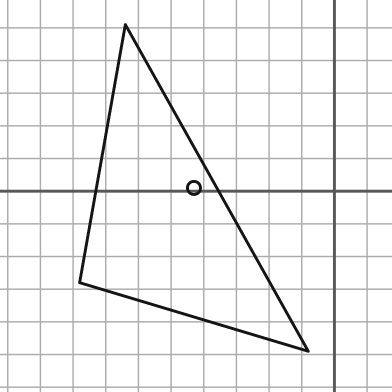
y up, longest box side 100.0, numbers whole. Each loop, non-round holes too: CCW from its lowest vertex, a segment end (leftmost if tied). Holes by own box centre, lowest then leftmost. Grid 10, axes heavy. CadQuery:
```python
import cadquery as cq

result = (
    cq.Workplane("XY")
    .moveTo(-8.0, -49.0)
    .lineTo(-64.0, 51.0)
    .lineTo(-78.0, -28.0)
    .close()
    .moveTo(-43.0, 1.0)
    .circle(2.0)
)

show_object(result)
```